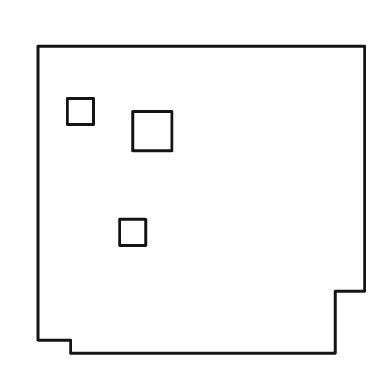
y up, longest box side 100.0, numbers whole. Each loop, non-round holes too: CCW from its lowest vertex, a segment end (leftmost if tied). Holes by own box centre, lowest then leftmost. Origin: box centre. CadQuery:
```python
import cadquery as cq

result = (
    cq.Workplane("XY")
    .moveTo(-40.0, -47.0)
    .lineTo(41.0, -47.0)
    .lineTo(41.0, -28.0)
    .lineTo(50.0, -28.0)
    .lineTo(50.0, 47.0)
    .lineTo(-50.0, 47.0)
    .lineTo(-50.0, -43.0)
    .lineTo(-40.0, -43.0)
    .close()
    .moveTo(-25.0, -14.0)
    .lineTo(-17.0, -14.0)
    .lineTo(-17.0, -6.0)
    .lineTo(-25.0, -6.0)
    .close()
    .moveTo(-21.0, 15.0)
    .lineTo(-9.0, 15.0)
    .lineTo(-9.0, 27.0)
    .lineTo(-21.0, 27.0)
    .close()
    .moveTo(-41.0, 23.0)
    .lineTo(-33.0, 23.0)
    .lineTo(-33.0, 31.0)
    .lineTo(-41.0, 31.0)
    .close()
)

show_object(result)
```